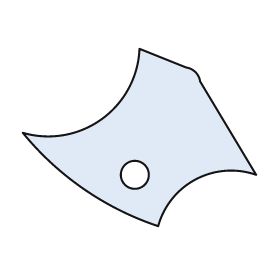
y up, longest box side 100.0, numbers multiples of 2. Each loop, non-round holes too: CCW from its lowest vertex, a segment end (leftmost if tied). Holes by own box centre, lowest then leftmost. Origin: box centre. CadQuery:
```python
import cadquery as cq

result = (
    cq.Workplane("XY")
    .moveTo(8.0, -38.0)
    .threePointArc((24.0, -18.0), (50.0, -16.0))
    .lineTo(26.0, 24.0)
    .threePointArc((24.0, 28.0), (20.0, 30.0))
    .lineTo(0.0, 38.0)
    .threePointArc((-16.0, 8.0), (-50.0, 2.0))
    .threePointArc((-24.0, -22.0), (8.0, -38.0))
    .close()
    .moveTo(-2.0, -16.0)
    .circle(6.0)
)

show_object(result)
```